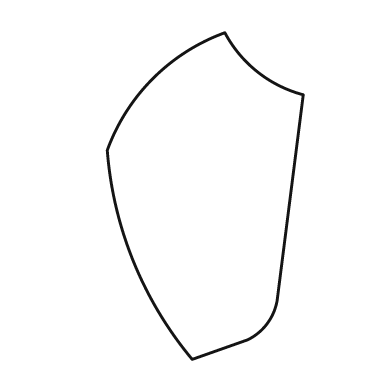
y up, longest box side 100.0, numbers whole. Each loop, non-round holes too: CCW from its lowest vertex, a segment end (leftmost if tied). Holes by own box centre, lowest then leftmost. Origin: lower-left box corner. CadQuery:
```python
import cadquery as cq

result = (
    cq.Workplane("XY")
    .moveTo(26.0, 0.0)
    .lineTo(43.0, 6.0)
    .threePointArc((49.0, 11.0), (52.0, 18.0))
    .lineTo(60.0, 81.0)
    .threePointArc((46.0, 88.0), (36.0, 100.0))
    .threePointArc((14.0, 86.0), (0.0, 64.0))
    .threePointArc((8.0, 30.0), (26.0, 0.0))
    .close()
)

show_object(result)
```